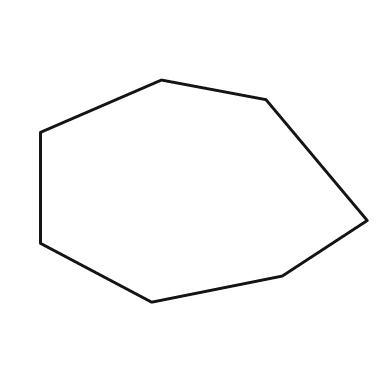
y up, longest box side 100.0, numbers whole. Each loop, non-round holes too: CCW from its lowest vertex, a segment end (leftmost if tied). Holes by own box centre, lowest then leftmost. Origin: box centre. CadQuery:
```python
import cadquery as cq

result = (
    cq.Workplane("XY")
    .moveTo(-16.0, -34.0)
    .lineTo(24.0, -26.0)
    .lineTo(50.0, -9.0)
    .lineTo(19.0, 28.0)
    .lineTo(-13.0, 34.0)
    .lineTo(-50.0, 18.0)
    .lineTo(-50.0, -16.0)
    .close()
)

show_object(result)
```